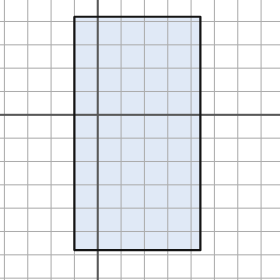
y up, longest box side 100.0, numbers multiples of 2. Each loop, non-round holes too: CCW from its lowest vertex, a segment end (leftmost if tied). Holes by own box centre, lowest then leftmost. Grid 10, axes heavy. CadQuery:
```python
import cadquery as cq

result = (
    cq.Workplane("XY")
    .moveTo(-10.0, -58.0)
    .lineTo(44.0, -58.0)
    .lineTo(44.0, 42.0)
    .lineTo(-10.0, 42.0)
    .close()
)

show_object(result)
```